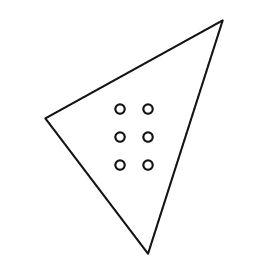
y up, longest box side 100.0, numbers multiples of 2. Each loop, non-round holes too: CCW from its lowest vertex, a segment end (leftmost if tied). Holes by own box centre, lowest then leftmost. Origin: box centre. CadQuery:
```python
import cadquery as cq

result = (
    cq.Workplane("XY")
    .moveTo(6.0, -50.0)
    .lineTo(38.0, 50.0)
    .lineTo(-38.0, 8.0)
    .close()
    .moveTo(-6.0, -12.0)
    .circle(2.0)
    .moveTo(6.0, -12.0)
    .circle(2.0)
    .moveTo(-6.0, 0.0)
    .circle(2.0)
    .moveTo(6.0, 0.0)
    .circle(2.0)
    .moveTo(-6.0, 12.0)
    .circle(2.0)
    .moveTo(6.0, 12.0)
    .circle(2.0)
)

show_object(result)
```